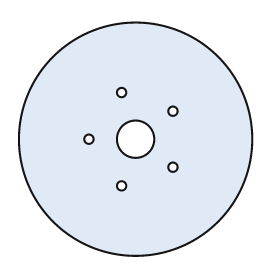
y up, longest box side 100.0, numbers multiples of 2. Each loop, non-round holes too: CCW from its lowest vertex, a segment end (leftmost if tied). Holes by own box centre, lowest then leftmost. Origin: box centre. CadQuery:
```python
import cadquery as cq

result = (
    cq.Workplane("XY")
    .moveTo(0.0, 0.0)
    .circle(50.0)
    .moveTo(-6.0, -20.0)
    .circle(2.0)
    .moveTo(16.0, -12.0)
    .circle(2.0)
    .moveTo(-20.0, 0.0)
    .circle(2.0)
    .moveTo(0.0, 0.0)
    .circle(8.0)
    .moveTo(16.0, 12.0)
    .circle(2.0)
    .moveTo(-6.0, 20.0)
    .circle(2.0)
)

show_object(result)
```